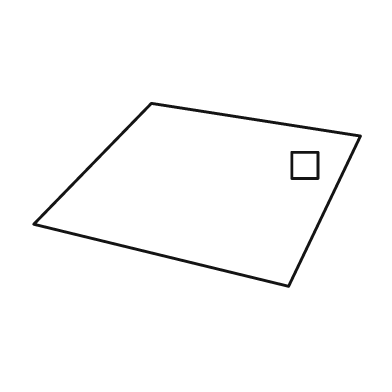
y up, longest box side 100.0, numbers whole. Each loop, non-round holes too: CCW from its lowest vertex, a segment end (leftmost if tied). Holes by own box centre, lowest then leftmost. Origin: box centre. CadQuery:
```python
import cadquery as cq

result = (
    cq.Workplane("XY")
    .moveTo(28.0, -28.0)
    .lineTo(50.0, 18.0)
    .lineTo(-14.0, 28.0)
    .lineTo(-50.0, -9.0)
    .close()
    .moveTo(29.0, 5.0)
    .lineTo(37.0, 5.0)
    .lineTo(37.0, 13.0)
    .lineTo(29.0, 13.0)
    .close()
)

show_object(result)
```